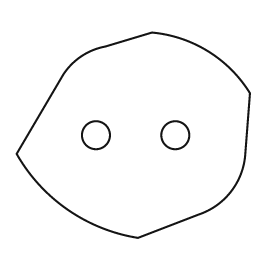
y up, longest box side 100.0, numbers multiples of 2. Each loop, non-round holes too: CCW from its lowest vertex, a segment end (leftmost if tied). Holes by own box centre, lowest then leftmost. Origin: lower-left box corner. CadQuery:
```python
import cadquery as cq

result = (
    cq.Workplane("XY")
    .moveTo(52.0, 0.0)
    .lineTo(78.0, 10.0)
    .threePointArc((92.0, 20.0), (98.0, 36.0))
    .lineTo(100.0, 62.0)
    .threePointArc((82.0, 80.0), (58.0, 88.0))
    .lineTo(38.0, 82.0)
    .threePointArc((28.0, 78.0), (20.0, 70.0))
    .lineTo(0.0, 36.0)
    .threePointArc((22.0, 12.0), (52.0, 0.0))
    .close()
    .moveTo(34.0, 44.0)
    .circle(6.0)
    .moveTo(68.0, 44.0)
    .circle(6.0)
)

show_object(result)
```